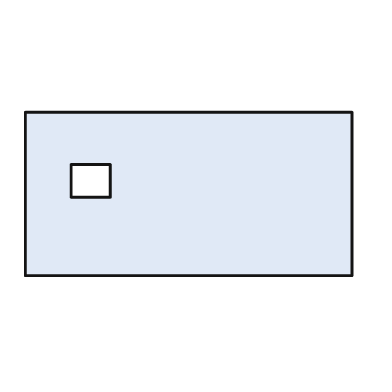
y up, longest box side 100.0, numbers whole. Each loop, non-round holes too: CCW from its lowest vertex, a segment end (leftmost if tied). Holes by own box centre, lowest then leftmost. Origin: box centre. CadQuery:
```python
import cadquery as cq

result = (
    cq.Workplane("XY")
    .moveTo(-50.0, -25.0)
    .lineTo(50.0, -25.0)
    .lineTo(50.0, 25.0)
    .lineTo(-50.0, 25.0)
    .close()
    .moveTo(-36.0, -1.0)
    .lineTo(-24.0, -1.0)
    .lineTo(-24.0, 9.0)
    .lineTo(-36.0, 9.0)
    .close()
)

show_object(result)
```